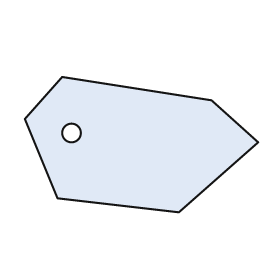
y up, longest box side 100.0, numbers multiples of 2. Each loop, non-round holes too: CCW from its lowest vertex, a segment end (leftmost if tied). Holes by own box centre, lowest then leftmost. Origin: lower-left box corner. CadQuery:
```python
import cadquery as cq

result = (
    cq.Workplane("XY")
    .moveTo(66.0, 0.0)
    .lineTo(100.0, 30.0)
    .lineTo(80.0, 48.0)
    .lineTo(16.0, 58.0)
    .lineTo(0.0, 40.0)
    .lineTo(14.0, 6.0)
    .close()
    .moveTo(20.0, 34.0)
    .circle(4.0)
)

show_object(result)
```